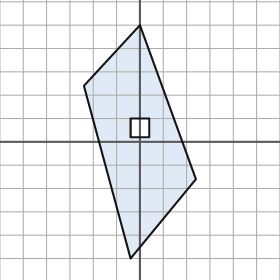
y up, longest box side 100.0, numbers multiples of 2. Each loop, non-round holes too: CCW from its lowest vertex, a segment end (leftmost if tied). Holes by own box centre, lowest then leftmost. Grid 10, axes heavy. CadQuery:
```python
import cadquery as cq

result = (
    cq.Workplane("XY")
    .moveTo(-4.0, -50.0)
    .lineTo(24.0, -16.0)
    .lineTo(0.0, 50.0)
    .lineTo(-24.0, 24.0)
    .close()
    .moveTo(-4.0, 2.0)
    .lineTo(4.0, 2.0)
    .lineTo(4.0, 10.0)
    .lineTo(-4.0, 10.0)
    .close()
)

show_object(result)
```